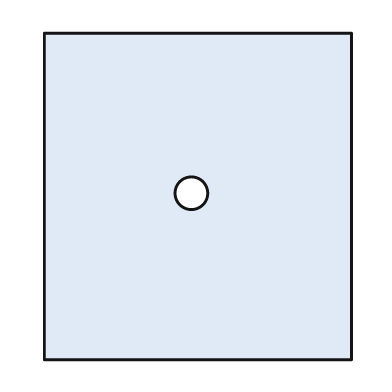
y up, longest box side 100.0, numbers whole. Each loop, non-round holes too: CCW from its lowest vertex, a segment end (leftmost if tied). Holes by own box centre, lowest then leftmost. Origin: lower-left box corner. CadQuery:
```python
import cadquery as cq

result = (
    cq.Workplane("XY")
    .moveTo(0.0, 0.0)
    .lineTo(94.0, 0.0)
    .lineTo(94.0, 100.0)
    .lineTo(0.0, 100.0)
    .close()
    .moveTo(45.0, 51.0)
    .circle(5.0)
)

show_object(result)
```